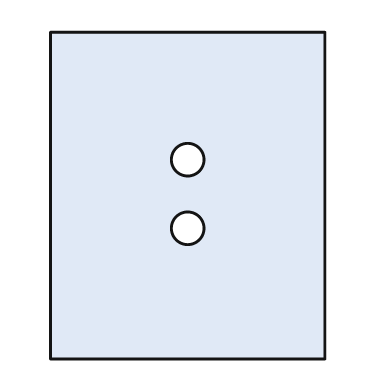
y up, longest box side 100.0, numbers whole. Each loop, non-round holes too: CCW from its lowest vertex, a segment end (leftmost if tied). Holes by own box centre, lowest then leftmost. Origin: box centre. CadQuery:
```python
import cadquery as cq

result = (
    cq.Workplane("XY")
    .moveTo(-42.0, -50.0)
    .lineTo(42.0, -50.0)
    .lineTo(42.0, 50.0)
    .lineTo(-42.0, 50.0)
    .close()
    .moveTo(0.0, -10.0)
    .circle(5.0)
    .moveTo(0.0, 11.0)
    .circle(5.0)
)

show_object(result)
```